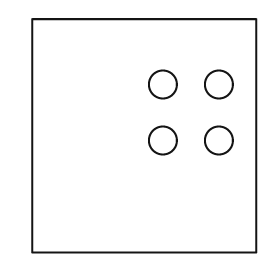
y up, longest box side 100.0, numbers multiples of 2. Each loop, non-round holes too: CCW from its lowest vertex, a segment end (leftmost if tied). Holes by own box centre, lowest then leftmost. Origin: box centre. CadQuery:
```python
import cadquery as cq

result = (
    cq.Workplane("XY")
    .moveTo(-48.0, -50.0)
    .lineTo(48.0, -50.0)
    .lineTo(48.0, 50.0)
    .lineTo(-48.0, 50.0)
    .close()
    .moveTo(8.0, -2.0)
    .circle(6.0)
    .moveTo(32.0, -2.0)
    .circle(6.0)
    .moveTo(8.0, 22.0)
    .circle(6.0)
    .moveTo(32.0, 22.0)
    .circle(6.0)
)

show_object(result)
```